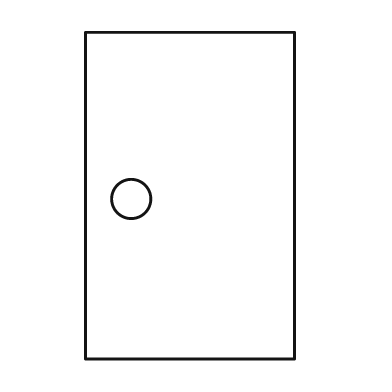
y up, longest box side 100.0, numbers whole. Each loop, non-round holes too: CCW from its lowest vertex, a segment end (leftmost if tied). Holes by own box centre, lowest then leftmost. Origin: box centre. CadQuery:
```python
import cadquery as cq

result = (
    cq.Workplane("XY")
    .moveTo(-32.0, -50.0)
    .lineTo(32.0, -50.0)
    .lineTo(32.0, 50.0)
    .lineTo(-32.0, 50.0)
    .close()
    .moveTo(-18.0, -1.0)
    .circle(6.0)
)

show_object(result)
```